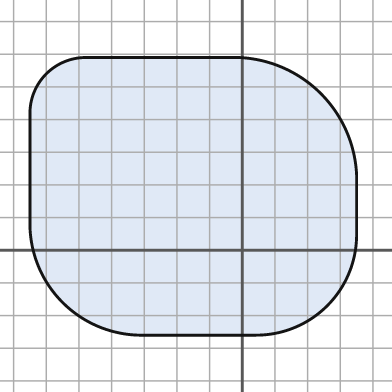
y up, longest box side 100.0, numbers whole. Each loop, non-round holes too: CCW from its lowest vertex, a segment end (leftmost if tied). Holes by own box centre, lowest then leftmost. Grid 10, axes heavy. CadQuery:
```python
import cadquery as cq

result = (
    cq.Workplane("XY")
    .moveTo(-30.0, -26.0)
    .lineTo(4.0, -26.0)
    .threePointArc((26.0, -17.0), (35.0, 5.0))
    .lineTo(35.0, 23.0)
    .threePointArc((24.0, 48.0), (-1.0, 59.0))
    .lineTo(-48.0, 59.0)
    .threePointArc((-60.0, 54.0), (-65.0, 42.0))
    .lineTo(-65.0, 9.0)
    .threePointArc((-55.0, -16.0), (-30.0, -26.0))
    .close()
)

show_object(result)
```